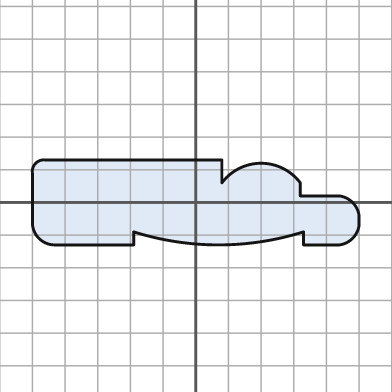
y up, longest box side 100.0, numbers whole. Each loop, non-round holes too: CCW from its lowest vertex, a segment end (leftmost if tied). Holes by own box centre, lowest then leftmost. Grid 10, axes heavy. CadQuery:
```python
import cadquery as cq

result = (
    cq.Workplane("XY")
    .moveTo(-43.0, -13.0)
    .lineTo(-19.0, -13.0)
    .lineTo(-19.0, -9.0)
    .threePointArc((7.0, -13.0), (33.0, -9.0))
    .lineTo(33.0, -13.0)
    .lineTo(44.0, -13.0)
    .threePointArc((48.0, -11.0), (50.0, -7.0))
    .lineTo(50.0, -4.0)
    .threePointArc((48.0, 0.0), (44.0, 2.0))
    .lineTo(32.0, 2.0)
    .lineTo(32.0, 6.0)
    .threePointArc((20.0, 12.0), (8.0, 6.0))
    .lineTo(8.0, 13.0)
    .lineTo(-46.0, 13.0)
    .threePointArc((-49.0, 12.0), (-50.0, 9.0))
    .lineTo(-50.0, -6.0)
    .threePointArc((-48.0, -11.0), (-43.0, -13.0))
    .close()
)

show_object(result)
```